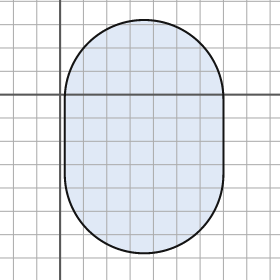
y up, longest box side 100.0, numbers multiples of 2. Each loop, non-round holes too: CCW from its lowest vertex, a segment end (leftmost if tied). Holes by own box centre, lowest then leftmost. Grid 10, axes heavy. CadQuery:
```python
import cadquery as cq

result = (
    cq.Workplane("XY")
    .moveTo(2.0, -34.0)
    .threePointArc((36.0, -68.0), (70.0, -34.0))
    .lineTo(70.0, -2.0)
    .threePointArc((36.0, 32.0), (2.0, -2.0))
    .close()
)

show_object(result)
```